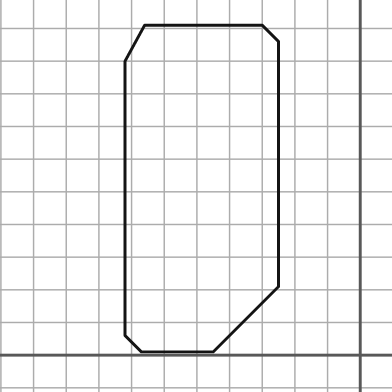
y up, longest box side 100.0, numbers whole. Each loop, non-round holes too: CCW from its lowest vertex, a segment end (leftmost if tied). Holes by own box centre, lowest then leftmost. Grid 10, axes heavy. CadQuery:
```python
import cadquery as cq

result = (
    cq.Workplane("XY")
    .moveTo(-67.0, 1.0)
    .lineTo(-45.0, 1.0)
    .lineTo(-25.0, 21.0)
    .lineTo(-25.0, 96.0)
    .lineTo(-30.0, 101.0)
    .lineTo(-66.0, 101.0)
    .lineTo(-72.0, 90.0)
    .lineTo(-72.0, 6.0)
    .close()
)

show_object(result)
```